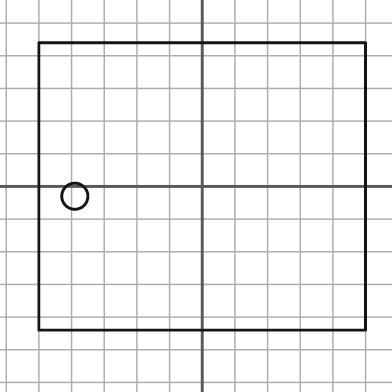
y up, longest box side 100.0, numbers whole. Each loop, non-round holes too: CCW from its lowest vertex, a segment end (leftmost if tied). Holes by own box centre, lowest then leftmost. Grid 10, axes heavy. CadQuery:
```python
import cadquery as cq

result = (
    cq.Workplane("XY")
    .moveTo(-50.0, -44.0)
    .lineTo(50.0, -44.0)
    .lineTo(50.0, 44.0)
    .lineTo(-50.0, 44.0)
    .close()
    .moveTo(-39.0, -3.0)
    .circle(4.0)
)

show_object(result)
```